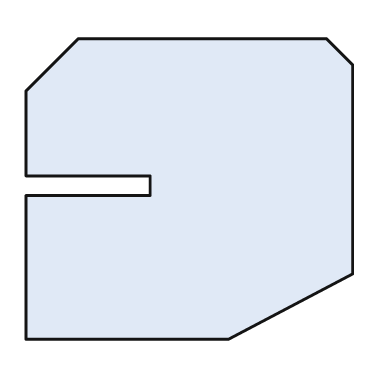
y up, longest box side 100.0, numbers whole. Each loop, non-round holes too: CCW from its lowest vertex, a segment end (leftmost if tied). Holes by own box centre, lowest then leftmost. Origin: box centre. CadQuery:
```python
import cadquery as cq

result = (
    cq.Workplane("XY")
    .moveTo(-50.0, -46.0)
    .lineTo(12.0, -46.0)
    .lineTo(50.0, -26.0)
    .lineTo(50.0, 38.0)
    .lineTo(42.0, 46.0)
    .lineTo(-34.0, 46.0)
    .lineTo(-50.0, 30.0)
    .lineTo(-50.0, 4.0)
    .lineTo(-12.0, 4.0)
    .lineTo(-12.0, -2.0)
    .lineTo(-50.0, -2.0)
    .close()
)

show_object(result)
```